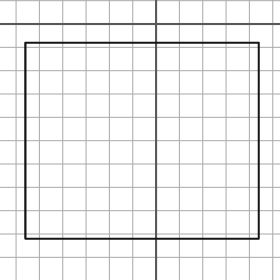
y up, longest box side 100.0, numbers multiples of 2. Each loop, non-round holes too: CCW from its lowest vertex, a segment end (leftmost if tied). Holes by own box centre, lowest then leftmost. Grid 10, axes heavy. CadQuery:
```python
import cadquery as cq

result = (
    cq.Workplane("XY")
    .moveTo(-56.0, -92.0)
    .lineTo(44.0, -92.0)
    .lineTo(44.0, -8.0)
    .lineTo(-56.0, -8.0)
    .close()
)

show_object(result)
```